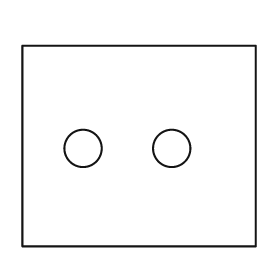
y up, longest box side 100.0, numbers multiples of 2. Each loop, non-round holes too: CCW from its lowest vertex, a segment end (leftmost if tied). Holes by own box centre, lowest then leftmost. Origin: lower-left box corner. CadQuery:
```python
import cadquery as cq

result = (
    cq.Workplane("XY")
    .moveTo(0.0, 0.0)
    .lineTo(100.0, 0.0)
    .lineTo(100.0, 86.0)
    .lineTo(0.0, 86.0)
    .close()
    .moveTo(26.0, 42.0)
    .circle(8.0)
    .moveTo(64.0, 42.0)
    .circle(8.0)
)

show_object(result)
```